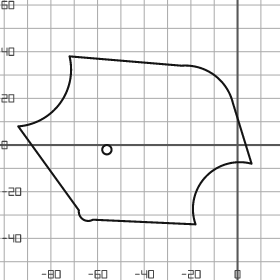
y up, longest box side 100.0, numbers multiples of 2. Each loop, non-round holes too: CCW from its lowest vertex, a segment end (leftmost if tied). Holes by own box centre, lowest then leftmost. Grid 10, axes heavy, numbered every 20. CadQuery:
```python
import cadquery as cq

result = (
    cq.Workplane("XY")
    .moveTo(-18.0, -34.0)
    .threePointArc((-14.0, -14.0), (6.0, -8.0))
    .lineTo(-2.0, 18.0)
    .threePointArc((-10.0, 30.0), (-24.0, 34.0))
    .lineTo(-72.0, 38.0)
    .threePointArc((-76.0, 18.0), (-94.0, 8.0))
    .lineTo(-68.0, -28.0)
    .threePointArc((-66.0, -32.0), (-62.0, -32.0))
    .close()
    .moveTo(-56.0, -2.0)
    .circle(2.0)
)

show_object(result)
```